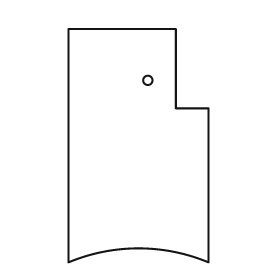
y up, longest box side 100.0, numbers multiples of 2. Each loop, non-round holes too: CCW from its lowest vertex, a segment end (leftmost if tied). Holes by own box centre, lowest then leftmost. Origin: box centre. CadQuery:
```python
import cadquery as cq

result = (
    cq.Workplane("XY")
    .moveTo(-30.0, -50.0)
    .threePointArc((0.0, -44.0), (30.0, -50.0))
    .lineTo(30.0, 16.0)
    .lineTo(16.0, 16.0)
    .lineTo(16.0, 50.0)
    .lineTo(-30.0, 50.0)
    .close()
    .moveTo(4.0, 28.0)
    .circle(2.0)
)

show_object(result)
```